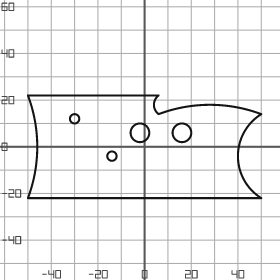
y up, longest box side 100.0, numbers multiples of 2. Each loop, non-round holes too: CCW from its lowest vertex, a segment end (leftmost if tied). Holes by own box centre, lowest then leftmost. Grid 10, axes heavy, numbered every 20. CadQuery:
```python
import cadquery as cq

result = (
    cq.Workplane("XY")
    .moveTo(-50.0, -22.0)
    .lineTo(50.0, -22.0)
    .threePointArc((40.0, -4.0), (50.0, 14.0))
    .threePointArc((28.0, 18.0), (6.0, 14.0))
    .threePointArc((4.0, 18.0), (6.0, 22.0))
    .lineTo(-50.0, 22.0)
    .threePointArc((-46.0, 0.0), (-50.0, -22.0))
    .close()
    .moveTo(-14.0, -4.0)
    .circle(2.0)
    .moveTo(-2.0, 6.0)
    .circle(4.0)
    .moveTo(16.0, 6.0)
    .circle(4.0)
    .moveTo(-30.0, 12.0)
    .circle(2.0)
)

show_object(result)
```